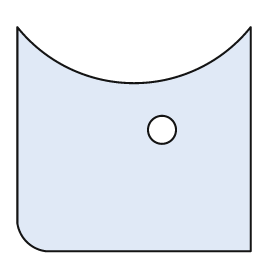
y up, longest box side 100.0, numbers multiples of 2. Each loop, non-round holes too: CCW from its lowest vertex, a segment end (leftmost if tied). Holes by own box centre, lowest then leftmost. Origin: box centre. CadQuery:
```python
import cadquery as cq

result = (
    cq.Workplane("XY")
    .moveTo(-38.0, -48.0)
    .lineTo(50.0, -48.0)
    .lineTo(50.0, 48.0)
    .threePointArc((0.0, 24.0), (-50.0, 48.0))
    .lineTo(-50.0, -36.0)
    .threePointArc((-46.0, -44.0), (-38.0, -48.0))
    .close()
    .moveTo(12.0, 4.0)
    .circle(6.0)
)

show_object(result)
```